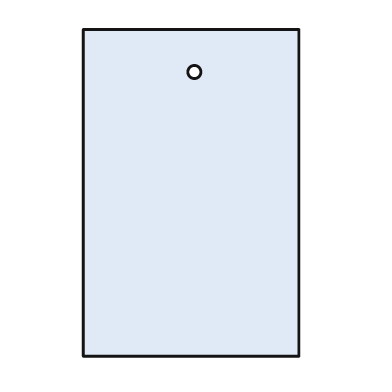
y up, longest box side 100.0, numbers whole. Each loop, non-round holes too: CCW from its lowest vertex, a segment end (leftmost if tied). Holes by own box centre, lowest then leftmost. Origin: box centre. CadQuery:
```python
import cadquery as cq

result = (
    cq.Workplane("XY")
    .moveTo(-33.0, -50.0)
    .lineTo(33.0, -50.0)
    .lineTo(33.0, 50.0)
    .lineTo(-33.0, 50.0)
    .close()
    .moveTo(1.0, 37.0)
    .circle(2.0)
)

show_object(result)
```